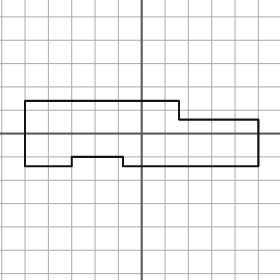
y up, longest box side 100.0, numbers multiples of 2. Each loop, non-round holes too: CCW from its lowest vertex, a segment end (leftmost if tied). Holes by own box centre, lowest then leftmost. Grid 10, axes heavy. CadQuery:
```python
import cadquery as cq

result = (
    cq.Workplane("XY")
    .moveTo(-50.0, -14.0)
    .lineTo(-30.0, -14.0)
    .lineTo(-30.0, -10.0)
    .lineTo(-8.0, -10.0)
    .lineTo(-8.0, -14.0)
    .lineTo(50.0, -14.0)
    .lineTo(50.0, 6.0)
    .lineTo(16.0, 6.0)
    .lineTo(16.0, 14.0)
    .lineTo(-50.0, 14.0)
    .close()
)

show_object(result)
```